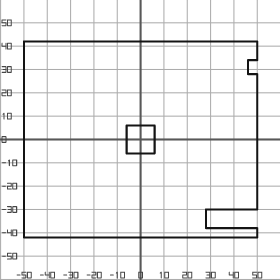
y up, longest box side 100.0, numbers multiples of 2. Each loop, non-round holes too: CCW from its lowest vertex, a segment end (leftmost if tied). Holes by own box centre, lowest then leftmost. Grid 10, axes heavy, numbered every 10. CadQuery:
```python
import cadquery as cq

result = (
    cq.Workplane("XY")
    .moveTo(-50.0, -42.0)
    .lineTo(50.0, -42.0)
    .lineTo(50.0, -38.0)
    .lineTo(28.0, -38.0)
    .lineTo(28.0, -30.0)
    .lineTo(50.0, -30.0)
    .lineTo(50.0, 28.0)
    .lineTo(46.0, 28.0)
    .lineTo(46.0, 34.0)
    .lineTo(50.0, 34.0)
    .lineTo(50.0, 42.0)
    .lineTo(-50.0, 42.0)
    .close()
    .moveTo(-6.0, -6.0)
    .lineTo(6.0, -6.0)
    .lineTo(6.0, 6.0)
    .lineTo(-6.0, 6.0)
    .close()
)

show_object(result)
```